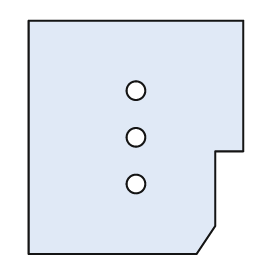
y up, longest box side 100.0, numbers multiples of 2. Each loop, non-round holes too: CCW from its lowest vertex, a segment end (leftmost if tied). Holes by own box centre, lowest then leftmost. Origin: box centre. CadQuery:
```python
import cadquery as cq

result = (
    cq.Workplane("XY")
    .moveTo(-46.0, -50.0)
    .lineTo(26.0, -50.0)
    .lineTo(34.0, -38.0)
    .lineTo(34.0, -6.0)
    .lineTo(46.0, -6.0)
    .lineTo(46.0, 50.0)
    .lineTo(-46.0, 50.0)
    .close()
    .moveTo(0.0, -20.0)
    .circle(4.0)
    .moveTo(0.0, 0.0)
    .circle(4.0)
    .moveTo(0.0, 20.0)
    .circle(4.0)
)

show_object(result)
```